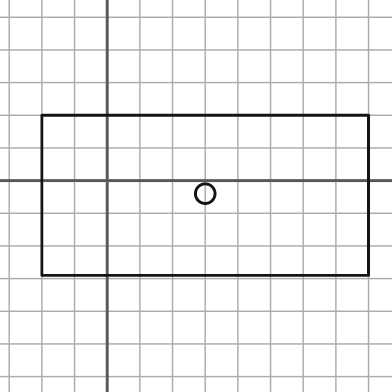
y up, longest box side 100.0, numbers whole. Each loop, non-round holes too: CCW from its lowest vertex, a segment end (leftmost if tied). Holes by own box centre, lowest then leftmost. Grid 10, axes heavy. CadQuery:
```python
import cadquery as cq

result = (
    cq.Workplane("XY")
    .moveTo(-20.0, -29.0)
    .lineTo(80.0, -29.0)
    .lineTo(80.0, 20.0)
    .lineTo(-20.0, 20.0)
    .close()
    .moveTo(30.0, -4.0)
    .circle(3.0)
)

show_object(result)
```